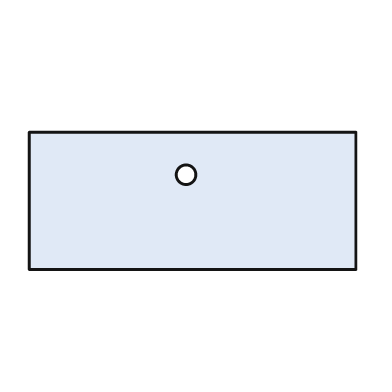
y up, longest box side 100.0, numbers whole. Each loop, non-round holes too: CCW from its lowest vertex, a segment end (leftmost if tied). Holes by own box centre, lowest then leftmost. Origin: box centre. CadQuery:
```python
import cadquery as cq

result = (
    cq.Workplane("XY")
    .moveTo(-50.0, -21.0)
    .lineTo(50.0, -21.0)
    .lineTo(50.0, 21.0)
    .lineTo(-50.0, 21.0)
    .close()
    .moveTo(-2.0, 8.0)
    .circle(3.0)
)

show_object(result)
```